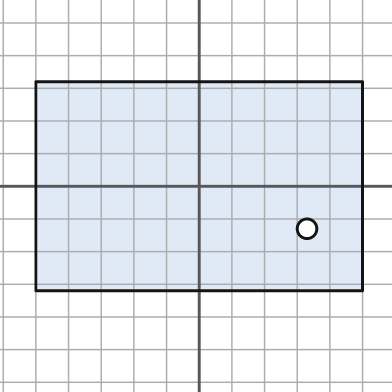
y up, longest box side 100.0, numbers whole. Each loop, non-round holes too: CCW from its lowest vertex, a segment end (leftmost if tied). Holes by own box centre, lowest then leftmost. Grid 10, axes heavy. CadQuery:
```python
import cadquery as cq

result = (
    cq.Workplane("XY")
    .moveTo(-50.0, -32.0)
    .lineTo(50.0, -32.0)
    .lineTo(50.0, 32.0)
    .lineTo(-50.0, 32.0)
    .close()
    .moveTo(33.0, -13.0)
    .circle(3.0)
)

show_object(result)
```